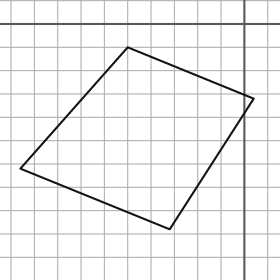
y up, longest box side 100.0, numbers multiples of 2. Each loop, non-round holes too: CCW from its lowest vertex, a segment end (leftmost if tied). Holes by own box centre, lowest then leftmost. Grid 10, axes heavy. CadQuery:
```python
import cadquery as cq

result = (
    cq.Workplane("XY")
    .moveTo(-32.0, -88.0)
    .lineTo(4.0, -32.0)
    .lineTo(-50.0, -10.0)
    .lineTo(-96.0, -62.0)
    .close()
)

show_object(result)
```